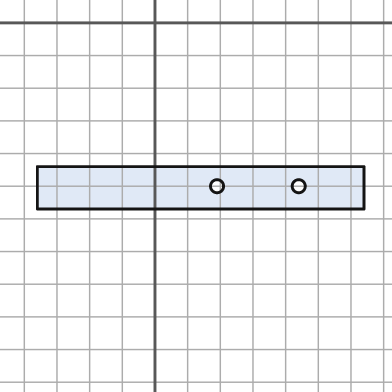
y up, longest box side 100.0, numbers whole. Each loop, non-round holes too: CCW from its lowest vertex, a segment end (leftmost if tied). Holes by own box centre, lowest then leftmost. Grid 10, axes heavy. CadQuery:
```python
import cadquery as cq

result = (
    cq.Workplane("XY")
    .moveTo(-36.0, -57.0)
    .lineTo(64.0, -57.0)
    .lineTo(64.0, -44.0)
    .lineTo(-36.0, -44.0)
    .close()
    .moveTo(19.0, -50.0)
    .circle(2.0)
    .moveTo(44.0, -50.0)
    .circle(2.0)
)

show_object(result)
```